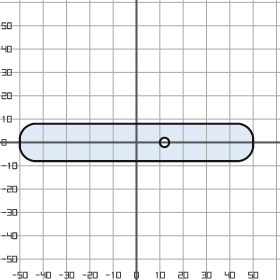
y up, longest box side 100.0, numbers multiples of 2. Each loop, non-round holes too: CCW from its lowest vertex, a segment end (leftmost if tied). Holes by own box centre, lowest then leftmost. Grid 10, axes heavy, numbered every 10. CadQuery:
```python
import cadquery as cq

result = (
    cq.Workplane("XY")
    .moveTo(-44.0, -8.0)
    .lineTo(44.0, -8.0)
    .threePointArc((48.0, -6.0), (50.0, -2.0))
    .lineTo(50.0, 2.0)
    .threePointArc((48.0, 6.0), (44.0, 8.0))
    .lineTo(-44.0, 8.0)
    .threePointArc((-48.0, 6.0), (-50.0, 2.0))
    .lineTo(-50.0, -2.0)
    .threePointArc((-48.0, -6.0), (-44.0, -8.0))
    .close()
    .moveTo(12.0, 0.0)
    .circle(2.0)
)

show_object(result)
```